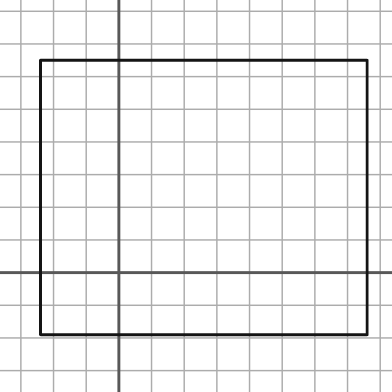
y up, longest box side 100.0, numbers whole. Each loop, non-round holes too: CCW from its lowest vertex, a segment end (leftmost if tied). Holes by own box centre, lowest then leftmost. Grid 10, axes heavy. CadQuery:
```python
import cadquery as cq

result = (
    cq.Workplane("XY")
    .moveTo(-24.0, -19.0)
    .lineTo(76.0, -19.0)
    .lineTo(76.0, 65.0)
    .lineTo(-24.0, 65.0)
    .close()
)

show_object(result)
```